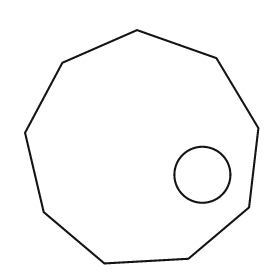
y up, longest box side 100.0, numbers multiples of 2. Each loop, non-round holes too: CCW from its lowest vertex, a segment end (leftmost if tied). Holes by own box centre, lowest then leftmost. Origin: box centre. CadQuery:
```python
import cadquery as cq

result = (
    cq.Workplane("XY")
    .moveTo(-16.0, -50.0)
    .lineTo(20.0, -48.0)
    .lineTo(46.0, -26.0)
    .lineTo(50.0, 8.0)
    .lineTo(32.0, 38.0)
    .lineTo(-2.0, 50.0)
    .lineTo(-34.0, 36.0)
    .lineTo(-50.0, 6.0)
    .lineTo(-42.0, -28.0)
    .close()
    .moveTo(26.0, -12.0)
    .circle(12.0)
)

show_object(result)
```